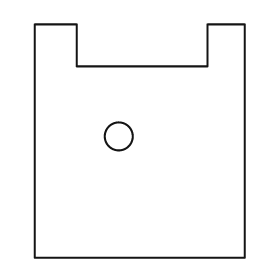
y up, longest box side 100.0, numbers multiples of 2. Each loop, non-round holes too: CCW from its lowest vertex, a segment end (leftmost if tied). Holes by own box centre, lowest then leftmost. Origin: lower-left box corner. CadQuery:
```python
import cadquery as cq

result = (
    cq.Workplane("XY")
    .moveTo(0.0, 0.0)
    .lineTo(90.0, 0.0)
    .lineTo(90.0, 100.0)
    .lineTo(74.0, 100.0)
    .lineTo(74.0, 82.0)
    .lineTo(18.0, 82.0)
    .lineTo(18.0, 100.0)
    .lineTo(0.0, 100.0)
    .close()
    .moveTo(36.0, 52.0)
    .circle(6.0)
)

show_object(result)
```